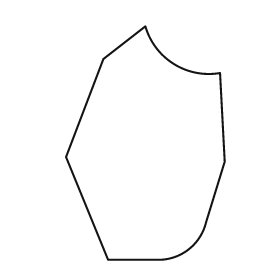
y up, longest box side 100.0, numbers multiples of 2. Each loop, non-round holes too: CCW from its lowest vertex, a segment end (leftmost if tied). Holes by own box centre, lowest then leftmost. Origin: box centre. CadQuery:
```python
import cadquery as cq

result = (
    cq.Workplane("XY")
    .moveTo(-16.0, -50.0)
    .lineTo(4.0, -50.0)
    .threePointArc((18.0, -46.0), (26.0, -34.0))
    .lineTo(34.0, -8.0)
    .lineTo(32.0, 30.0)
    .threePointArc((12.0, 34.0), (0.0, 50.0))
    .lineTo(-18.0, 36.0)
    .lineTo(-34.0, -6.0)
    .close()
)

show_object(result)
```